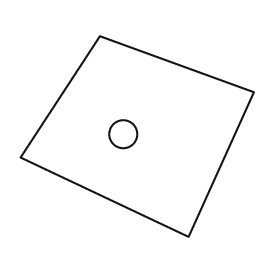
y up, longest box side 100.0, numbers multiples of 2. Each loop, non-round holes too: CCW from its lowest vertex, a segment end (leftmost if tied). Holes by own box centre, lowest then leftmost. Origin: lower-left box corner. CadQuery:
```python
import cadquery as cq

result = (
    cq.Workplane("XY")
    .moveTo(72.0, 0.0)
    .lineTo(100.0, 62.0)
    .lineTo(34.0, 86.0)
    .lineTo(0.0, 34.0)
    .close()
    .moveTo(44.0, 44.0)
    .circle(6.0)
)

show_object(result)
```